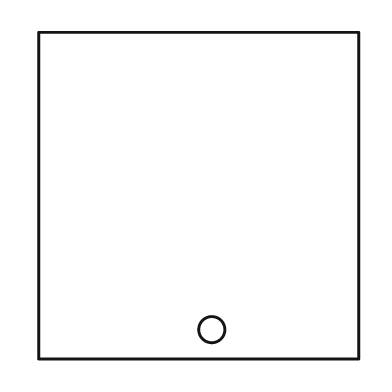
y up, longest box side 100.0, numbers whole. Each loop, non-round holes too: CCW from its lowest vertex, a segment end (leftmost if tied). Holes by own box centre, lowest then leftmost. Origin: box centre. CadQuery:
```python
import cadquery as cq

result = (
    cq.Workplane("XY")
    .moveTo(-49.0, -50.0)
    .lineTo(49.0, -50.0)
    .lineTo(49.0, 50.0)
    .lineTo(-49.0, 50.0)
    .close()
    .moveTo(4.0, -41.0)
    .circle(4.0)
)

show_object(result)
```